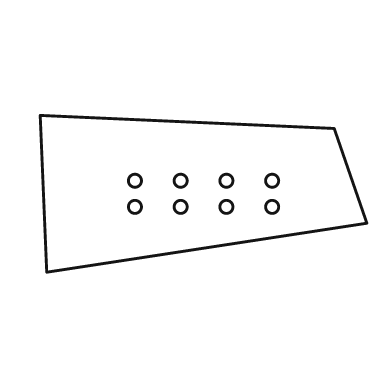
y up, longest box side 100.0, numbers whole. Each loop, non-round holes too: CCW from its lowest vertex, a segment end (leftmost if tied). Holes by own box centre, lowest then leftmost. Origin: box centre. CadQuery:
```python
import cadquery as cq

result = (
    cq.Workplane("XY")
    .moveTo(-48.0, -24.0)
    .lineTo(50.0, -9.0)
    .lineTo(40.0, 20.0)
    .lineTo(-50.0, 24.0)
    .close()
    .moveTo(-21.0, -4.0)
    .circle(2.0)
    .moveTo(-7.0, -4.0)
    .circle(2.0)
    .moveTo(7.0, -4.0)
    .circle(2.0)
    .moveTo(21.0, -4.0)
    .circle(2.0)
    .moveTo(-21.0, 4.0)
    .circle(2.0)
    .moveTo(-7.0, 4.0)
    .circle(2.0)
    .moveTo(7.0, 4.0)
    .circle(2.0)
    .moveTo(21.0, 4.0)
    .circle(2.0)
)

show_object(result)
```